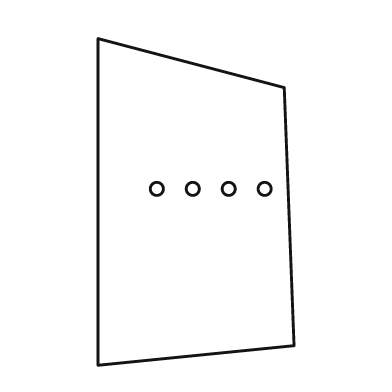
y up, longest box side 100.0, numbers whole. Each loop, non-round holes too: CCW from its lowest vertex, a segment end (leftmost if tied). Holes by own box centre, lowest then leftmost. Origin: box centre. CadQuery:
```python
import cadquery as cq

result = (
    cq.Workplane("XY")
    .moveTo(-30.0, -50.0)
    .lineTo(30.0, -44.0)
    .lineTo(27.0, 35.0)
    .lineTo(-30.0, 50.0)
    .close()
    .moveTo(-12.0, 4.0)
    .circle(2.0)
    .moveTo(-1.0, 4.0)
    .circle(2.0)
    .moveTo(10.0, 4.0)
    .circle(2.0)
    .moveTo(21.0, 4.0)
    .circle(2.0)
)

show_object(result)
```